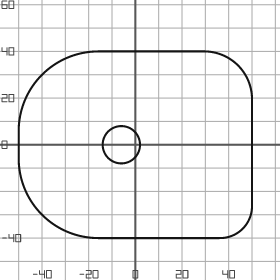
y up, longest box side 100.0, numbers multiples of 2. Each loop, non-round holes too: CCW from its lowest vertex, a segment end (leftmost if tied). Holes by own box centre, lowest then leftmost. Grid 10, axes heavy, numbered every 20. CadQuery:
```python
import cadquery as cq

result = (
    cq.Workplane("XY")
    .moveTo(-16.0, -40.0)
    .lineTo(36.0, -40.0)
    .threePointArc((46.0, -36.0), (50.0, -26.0))
    .lineTo(50.0, 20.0)
    .threePointArc((44.0, 34.0), (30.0, 40.0))
    .lineTo(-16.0, 40.0)
    .threePointArc((-40.0, 30.0), (-50.0, 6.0))
    .lineTo(-50.0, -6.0)
    .threePointArc((-40.0, -30.0), (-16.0, -40.0))
    .close()
    .moveTo(-6.0, 0.0)
    .circle(8.0)
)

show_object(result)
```